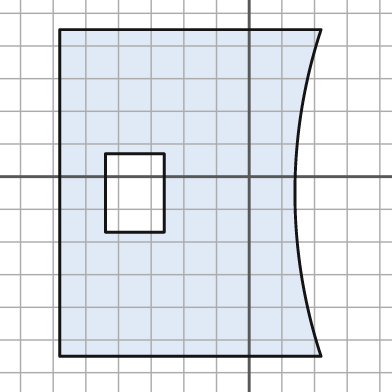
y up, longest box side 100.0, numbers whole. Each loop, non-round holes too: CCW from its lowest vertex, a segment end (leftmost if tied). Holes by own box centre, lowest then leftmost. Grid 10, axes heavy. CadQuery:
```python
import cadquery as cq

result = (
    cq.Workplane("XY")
    .moveTo(-58.0, -55.0)
    .lineTo(22.0, -55.0)
    .threePointArc((14.0, -5.0), (22.0, 45.0))
    .lineTo(-58.0, 45.0)
    .close()
    .moveTo(-44.0, -17.0)
    .lineTo(-26.0, -17.0)
    .lineTo(-26.0, 7.0)
    .lineTo(-44.0, 7.0)
    .close()
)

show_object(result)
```